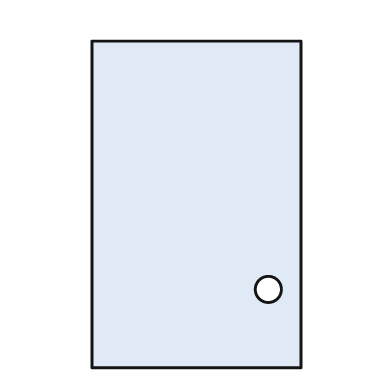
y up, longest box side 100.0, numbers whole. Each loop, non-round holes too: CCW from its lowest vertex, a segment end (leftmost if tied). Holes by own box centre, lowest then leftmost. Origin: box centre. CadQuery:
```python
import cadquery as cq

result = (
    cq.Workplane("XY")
    .moveTo(-32.0, -50.0)
    .lineTo(32.0, -50.0)
    .lineTo(32.0, 50.0)
    .lineTo(-32.0, 50.0)
    .close()
    .moveTo(22.0, -26.0)
    .circle(4.0)
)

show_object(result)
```